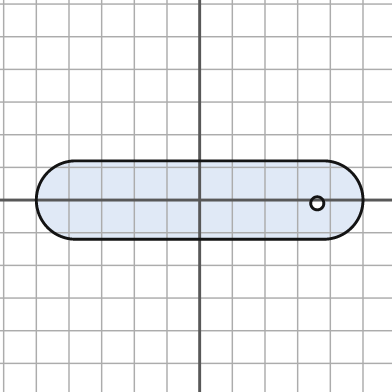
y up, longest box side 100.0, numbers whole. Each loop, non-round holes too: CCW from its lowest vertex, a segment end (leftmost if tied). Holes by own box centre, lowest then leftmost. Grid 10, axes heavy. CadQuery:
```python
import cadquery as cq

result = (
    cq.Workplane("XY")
    .moveTo(-38.0, -12.0)
    .lineTo(38.0, -12.0)
    .threePointArc((50.0, 0.0), (38.0, 12.0))
    .lineTo(-38.0, 12.0)
    .threePointArc((-50.0, 0.0), (-38.0, -12.0))
    .close()
    .moveTo(36.0, -1.0)
    .circle(2.0)
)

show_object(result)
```